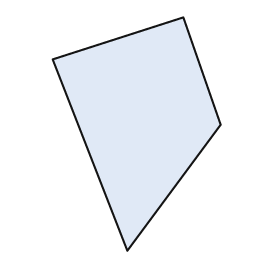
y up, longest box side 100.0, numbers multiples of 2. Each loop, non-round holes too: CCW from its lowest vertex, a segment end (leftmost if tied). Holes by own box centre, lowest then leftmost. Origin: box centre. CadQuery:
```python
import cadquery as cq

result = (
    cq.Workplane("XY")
    .moveTo(-4.0, -50.0)
    .lineTo(36.0, 4.0)
    .lineTo(20.0, 50.0)
    .lineTo(-36.0, 32.0)
    .close()
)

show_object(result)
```